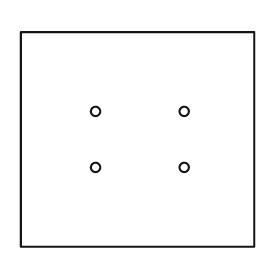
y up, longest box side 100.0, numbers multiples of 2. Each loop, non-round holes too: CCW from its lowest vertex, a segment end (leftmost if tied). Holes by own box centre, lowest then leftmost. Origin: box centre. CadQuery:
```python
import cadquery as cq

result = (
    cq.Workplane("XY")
    .moveTo(-50.0, -46.0)
    .lineTo(50.0, -46.0)
    .lineTo(50.0, 46.0)
    .lineTo(-50.0, 46.0)
    .close()
    .moveTo(-18.0, -12.0)
    .circle(2.0)
    .moveTo(20.0, -12.0)
    .circle(2.0)
    .moveTo(-18.0, 12.0)
    .circle(2.0)
    .moveTo(20.0, 12.0)
    .circle(2.0)
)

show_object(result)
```